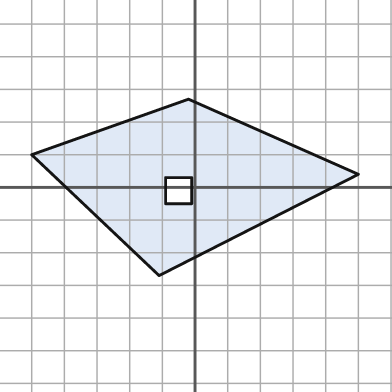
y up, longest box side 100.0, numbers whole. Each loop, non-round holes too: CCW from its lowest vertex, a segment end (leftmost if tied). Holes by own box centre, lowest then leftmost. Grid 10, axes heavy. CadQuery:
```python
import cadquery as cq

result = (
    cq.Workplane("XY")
    .moveTo(-11.0, -27.0)
    .lineTo(50.0, 4.0)
    .lineTo(-2.0, 27.0)
    .lineTo(-50.0, 10.0)
    .close()
    .moveTo(-9.0, -5.0)
    .lineTo(-1.0, -5.0)
    .lineTo(-1.0, 3.0)
    .lineTo(-9.0, 3.0)
    .close()
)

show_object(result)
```